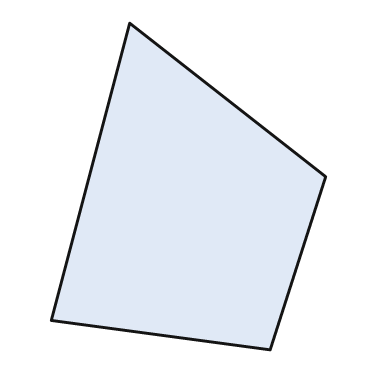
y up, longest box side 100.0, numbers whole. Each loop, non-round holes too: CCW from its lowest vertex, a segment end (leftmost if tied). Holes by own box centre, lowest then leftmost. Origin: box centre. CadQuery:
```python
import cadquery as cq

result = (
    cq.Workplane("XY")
    .moveTo(25.0, -50.0)
    .lineTo(42.0, 3.0)
    .lineTo(-18.0, 50.0)
    .lineTo(-42.0, -41.0)
    .close()
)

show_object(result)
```